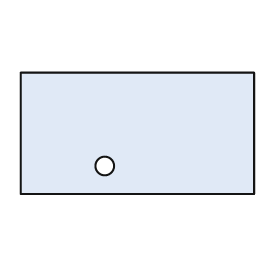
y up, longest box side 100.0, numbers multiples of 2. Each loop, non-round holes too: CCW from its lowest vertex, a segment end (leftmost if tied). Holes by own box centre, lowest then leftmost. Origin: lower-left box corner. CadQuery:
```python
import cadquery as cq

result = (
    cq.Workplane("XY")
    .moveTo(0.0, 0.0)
    .lineTo(100.0, 0.0)
    .lineTo(100.0, 52.0)
    .lineTo(0.0, 52.0)
    .close()
    .moveTo(36.0, 12.0)
    .circle(4.0)
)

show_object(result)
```